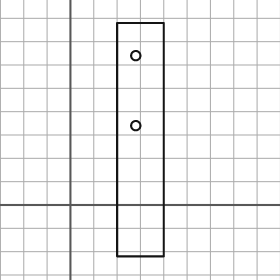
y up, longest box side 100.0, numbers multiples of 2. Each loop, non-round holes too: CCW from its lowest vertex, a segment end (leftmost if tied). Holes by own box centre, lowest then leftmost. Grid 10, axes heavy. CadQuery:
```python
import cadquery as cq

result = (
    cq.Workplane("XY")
    .moveTo(20.0, -22.0)
    .lineTo(40.0, -22.0)
    .lineTo(40.0, 78.0)
    .lineTo(20.0, 78.0)
    .close()
    .moveTo(28.0, 34.0)
    .circle(2.0)
    .moveTo(28.0, 64.0)
    .circle(2.0)
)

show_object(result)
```